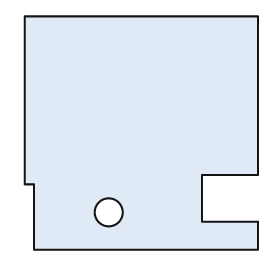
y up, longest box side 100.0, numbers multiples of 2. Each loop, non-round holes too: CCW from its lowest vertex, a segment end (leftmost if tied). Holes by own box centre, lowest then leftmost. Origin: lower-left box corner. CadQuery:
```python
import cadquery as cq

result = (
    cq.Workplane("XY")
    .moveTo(4.0, 0.0)
    .lineTo(100.0, 0.0)
    .lineTo(100.0, 12.0)
    .lineTo(76.0, 12.0)
    .lineTo(76.0, 32.0)
    .lineTo(100.0, 32.0)
    .lineTo(100.0, 100.0)
    .lineTo(0.0, 100.0)
    .lineTo(0.0, 28.0)
    .lineTo(4.0, 28.0)
    .close()
    .moveTo(36.0, 16.0)
    .circle(6.0)
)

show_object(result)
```